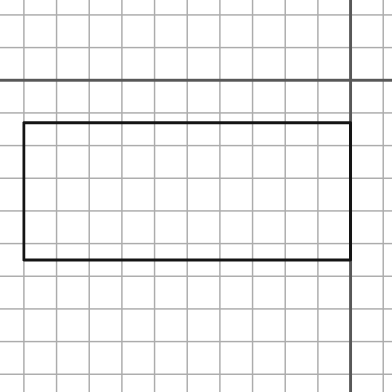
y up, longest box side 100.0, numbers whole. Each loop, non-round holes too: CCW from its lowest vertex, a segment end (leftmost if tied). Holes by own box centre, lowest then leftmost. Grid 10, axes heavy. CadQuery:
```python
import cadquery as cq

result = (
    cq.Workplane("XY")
    .moveTo(-100.0, -55.0)
    .lineTo(0.0, -55.0)
    .lineTo(0.0, -13.0)
    .lineTo(-100.0, -13.0)
    .close()
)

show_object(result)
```